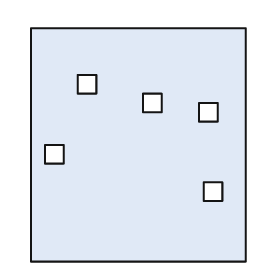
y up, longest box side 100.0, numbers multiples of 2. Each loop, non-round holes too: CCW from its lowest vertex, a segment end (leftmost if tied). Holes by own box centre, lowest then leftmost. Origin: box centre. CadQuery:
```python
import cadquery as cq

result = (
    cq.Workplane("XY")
    .moveTo(-46.0, -50.0)
    .lineTo(46.0, -50.0)
    .lineTo(46.0, 50.0)
    .lineTo(-46.0, 50.0)
    .close()
    .moveTo(28.0, -24.0)
    .lineTo(36.0, -24.0)
    .lineTo(36.0, -16.0)
    .lineTo(28.0, -16.0)
    .close()
    .moveTo(-40.0, -8.0)
    .lineTo(-32.0, -8.0)
    .lineTo(-32.0, 0.0)
    .lineTo(-40.0, 0.0)
    .close()
    .moveTo(26.0, 10.0)
    .lineTo(34.0, 10.0)
    .lineTo(34.0, 18.0)
    .lineTo(26.0, 18.0)
    .close()
    .moveTo(2.0, 14.0)
    .lineTo(10.0, 14.0)
    .lineTo(10.0, 22.0)
    .lineTo(2.0, 22.0)
    .close()
    .moveTo(-26.0, 22.0)
    .lineTo(-18.0, 22.0)
    .lineTo(-18.0, 30.0)
    .lineTo(-26.0, 30.0)
    .close()
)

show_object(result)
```